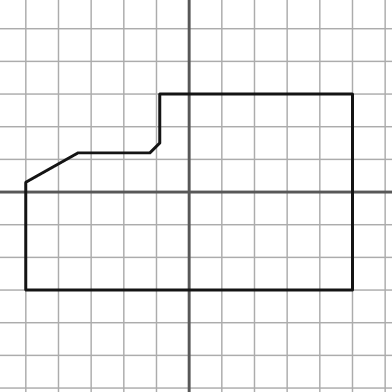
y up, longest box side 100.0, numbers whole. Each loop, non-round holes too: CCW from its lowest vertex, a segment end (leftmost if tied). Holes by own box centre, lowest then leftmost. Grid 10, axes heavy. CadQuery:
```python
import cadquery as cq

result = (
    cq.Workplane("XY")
    .moveTo(-50.0, -30.0)
    .lineTo(50.0, -30.0)
    .lineTo(50.0, 30.0)
    .lineTo(-9.0, 30.0)
    .lineTo(-9.0, 15.0)
    .lineTo(-12.0, 12.0)
    .lineTo(-34.0, 12.0)
    .lineTo(-50.0, 3.0)
    .close()
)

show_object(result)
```